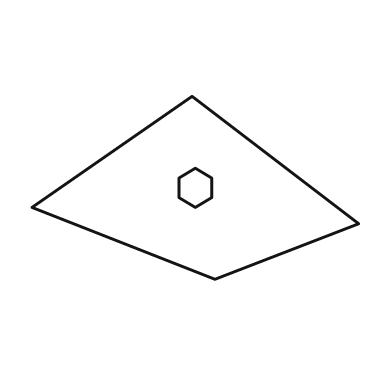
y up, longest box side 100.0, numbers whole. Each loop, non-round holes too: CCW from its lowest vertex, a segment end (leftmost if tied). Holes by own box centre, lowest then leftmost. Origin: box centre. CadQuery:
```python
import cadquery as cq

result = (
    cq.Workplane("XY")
    .moveTo(6.0, -28.0)
    .lineTo(50.0, -11.0)
    .lineTo(-1.0, 28.0)
    .lineTo(-50.0, -6.0)
    .close()
    .moveTo(0.0, -6.0)
    .lineTo(5.0, -3.0)
    .lineTo(5.0, 3.0)
    .lineTo(0.0, 6.0)
    .lineTo(-5.0, 3.0)
    .lineTo(-5.0, -3.0)
    .close()
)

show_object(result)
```